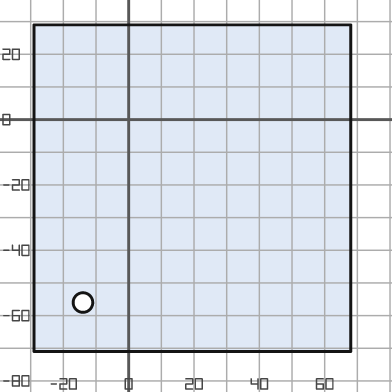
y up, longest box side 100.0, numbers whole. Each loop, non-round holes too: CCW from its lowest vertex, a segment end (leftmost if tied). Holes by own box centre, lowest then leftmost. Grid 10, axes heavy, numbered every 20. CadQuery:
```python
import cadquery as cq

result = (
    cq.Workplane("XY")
    .moveTo(-29.0, -71.0)
    .lineTo(68.0, -71.0)
    .lineTo(68.0, 29.0)
    .lineTo(-29.0, 29.0)
    .close()
    .moveTo(-14.0, -56.0)
    .circle(3.0)
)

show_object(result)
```